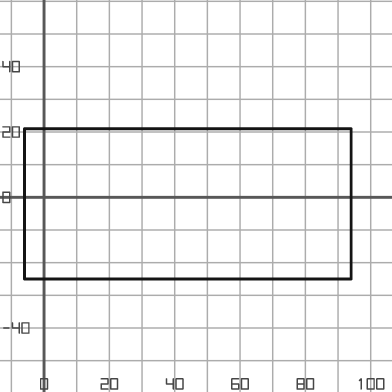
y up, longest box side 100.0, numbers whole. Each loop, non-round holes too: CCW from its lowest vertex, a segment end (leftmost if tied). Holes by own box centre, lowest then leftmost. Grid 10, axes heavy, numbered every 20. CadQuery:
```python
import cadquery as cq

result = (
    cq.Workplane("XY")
    .moveTo(-6.0, -25.0)
    .lineTo(94.0, -25.0)
    .lineTo(94.0, 21.0)
    .lineTo(-6.0, 21.0)
    .close()
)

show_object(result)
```